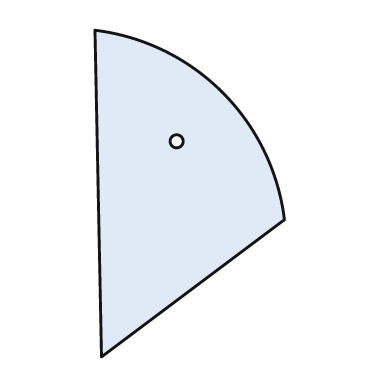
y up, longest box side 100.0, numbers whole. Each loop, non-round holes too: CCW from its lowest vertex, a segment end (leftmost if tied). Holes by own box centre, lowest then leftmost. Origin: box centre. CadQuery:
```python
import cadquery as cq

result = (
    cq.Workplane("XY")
    .moveTo(-27.0, -50.0)
    .lineTo(29.0, -8.0)
    .threePointArc((10.0, 31.0), (-29.0, 50.0))
    .close()
    .moveTo(-4.0, 16.0)
    .circle(2.0)
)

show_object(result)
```